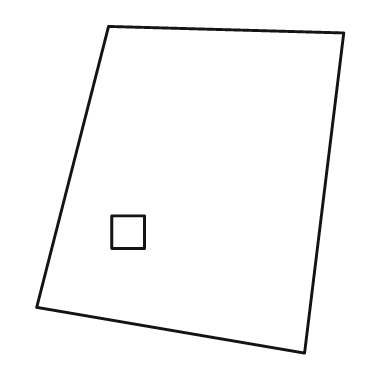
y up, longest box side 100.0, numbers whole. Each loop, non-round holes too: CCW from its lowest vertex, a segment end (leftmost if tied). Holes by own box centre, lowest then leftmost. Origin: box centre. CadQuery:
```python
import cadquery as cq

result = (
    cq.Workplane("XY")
    .moveTo(35.0, -50.0)
    .lineTo(47.0, 48.0)
    .lineTo(-25.0, 50.0)
    .lineTo(-47.0, -36.0)
    .close()
    .moveTo(-24.0, -18.0)
    .lineTo(-14.0, -18.0)
    .lineTo(-14.0, -8.0)
    .lineTo(-24.0, -8.0)
    .close()
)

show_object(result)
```